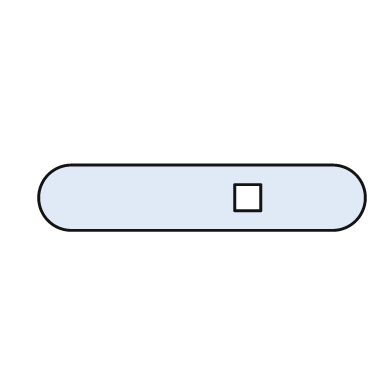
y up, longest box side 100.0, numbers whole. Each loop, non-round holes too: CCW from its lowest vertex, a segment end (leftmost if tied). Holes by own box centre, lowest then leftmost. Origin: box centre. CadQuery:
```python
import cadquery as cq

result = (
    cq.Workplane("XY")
    .moveTo(-40.0, -10.0)
    .lineTo(40.0, -10.0)
    .threePointArc((50.0, 0.0), (40.0, 10.0))
    .lineTo(-40.0, 10.0)
    .threePointArc((-50.0, 0.0), (-40.0, -10.0))
    .close()
    .moveTo(10.0, -4.0)
    .lineTo(18.0, -4.0)
    .lineTo(18.0, 4.0)
    .lineTo(10.0, 4.0)
    .close()
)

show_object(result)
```